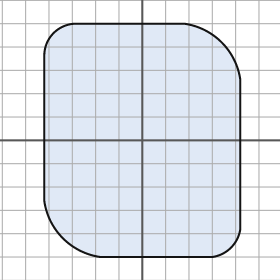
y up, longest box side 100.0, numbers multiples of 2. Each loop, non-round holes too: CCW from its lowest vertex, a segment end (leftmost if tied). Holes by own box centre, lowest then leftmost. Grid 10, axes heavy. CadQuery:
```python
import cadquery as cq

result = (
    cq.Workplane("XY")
    .moveTo(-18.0, -50.0)
    .lineTo(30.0, -50.0)
    .threePointArc((38.0, -46.0), (42.0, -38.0))
    .lineTo(42.0, 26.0)
    .threePointArc((34.0, 42.0), (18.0, 50.0))
    .lineTo(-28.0, 50.0)
    .threePointArc((-38.0, 46.0), (-42.0, 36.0))
    .lineTo(-42.0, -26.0)
    .threePointArc((-34.0, -42.0), (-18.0, -50.0))
    .close()
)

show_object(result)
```